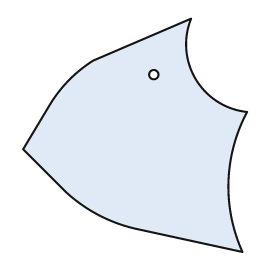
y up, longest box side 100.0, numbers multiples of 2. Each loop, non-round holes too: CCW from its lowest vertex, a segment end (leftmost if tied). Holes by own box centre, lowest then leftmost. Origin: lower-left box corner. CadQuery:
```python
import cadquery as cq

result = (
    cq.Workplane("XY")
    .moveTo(94.0, 0.0)
    .threePointArc((88.0, 30.0), (96.0, 60.0))
    .threePointArc((74.0, 74.0), (72.0, 100.0))
    .lineTo(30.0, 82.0)
    .threePointArc((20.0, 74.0), (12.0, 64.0))
    .lineTo(0.0, 44.0)
    .lineTo(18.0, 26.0)
    .threePointArc((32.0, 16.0), (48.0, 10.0))
    .close()
    .moveTo(56.0, 76.0)
    .circle(2.0)
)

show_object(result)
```